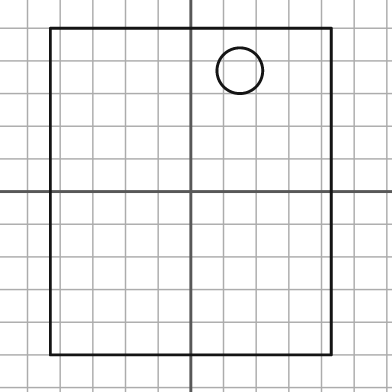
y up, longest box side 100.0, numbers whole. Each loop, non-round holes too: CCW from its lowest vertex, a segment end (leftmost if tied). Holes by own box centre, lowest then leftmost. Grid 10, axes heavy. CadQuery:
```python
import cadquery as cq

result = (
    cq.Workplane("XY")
    .moveTo(-43.0, -50.0)
    .lineTo(43.0, -50.0)
    .lineTo(43.0, 50.0)
    .lineTo(-43.0, 50.0)
    .close()
    .moveTo(15.0, 37.0)
    .circle(7.0)
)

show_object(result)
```